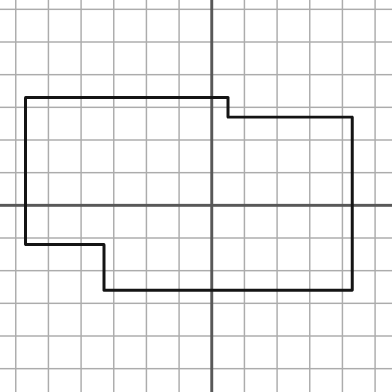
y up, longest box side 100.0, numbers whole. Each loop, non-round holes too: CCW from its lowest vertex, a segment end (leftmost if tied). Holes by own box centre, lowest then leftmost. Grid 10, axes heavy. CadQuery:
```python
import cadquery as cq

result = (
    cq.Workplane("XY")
    .moveTo(-33.0, -26.0)
    .lineTo(43.0, -26.0)
    .lineTo(43.0, 27.0)
    .lineTo(5.0, 27.0)
    .lineTo(5.0, 33.0)
    .lineTo(-57.0, 33.0)
    .lineTo(-57.0, -12.0)
    .lineTo(-33.0, -12.0)
    .close()
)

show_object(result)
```